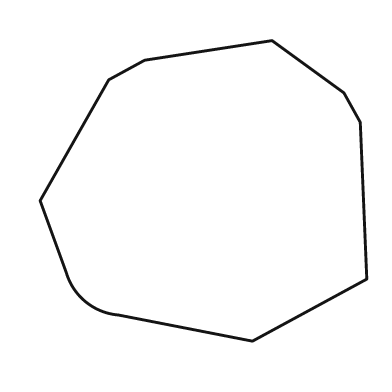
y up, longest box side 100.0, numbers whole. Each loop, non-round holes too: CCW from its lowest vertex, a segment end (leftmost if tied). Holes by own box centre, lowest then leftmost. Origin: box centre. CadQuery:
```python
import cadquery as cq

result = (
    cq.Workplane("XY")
    .moveTo(15.0, -46.0)
    .lineTo(50.0, -27.0)
    .lineTo(48.0, 21.0)
    .lineTo(43.0, 30.0)
    .lineTo(21.0, 46.0)
    .lineTo(-18.0, 40.0)
    .lineTo(-29.0, 34.0)
    .lineTo(-50.0, -3.0)
    .lineTo(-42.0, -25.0)
    .threePointArc((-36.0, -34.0), (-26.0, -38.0))
    .close()
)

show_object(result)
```